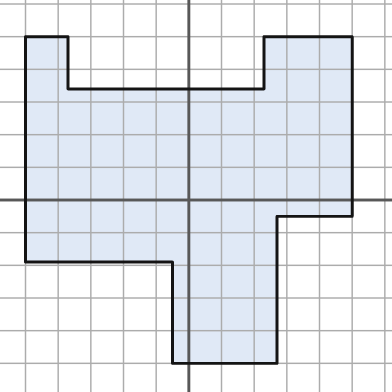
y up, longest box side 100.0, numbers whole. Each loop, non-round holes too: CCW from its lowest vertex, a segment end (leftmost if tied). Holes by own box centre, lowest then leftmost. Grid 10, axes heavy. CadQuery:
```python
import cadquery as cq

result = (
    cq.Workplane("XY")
    .moveTo(-5.0, -50.0)
    .lineTo(27.0, -50.0)
    .lineTo(27.0, -5.0)
    .lineTo(50.0, -5.0)
    .lineTo(50.0, 50.0)
    .lineTo(23.0, 50.0)
    .lineTo(23.0, 34.0)
    .lineTo(-37.0, 34.0)
    .lineTo(-37.0, 50.0)
    .lineTo(-50.0, 50.0)
    .lineTo(-50.0, -19.0)
    .lineTo(-5.0, -19.0)
    .close()
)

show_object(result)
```